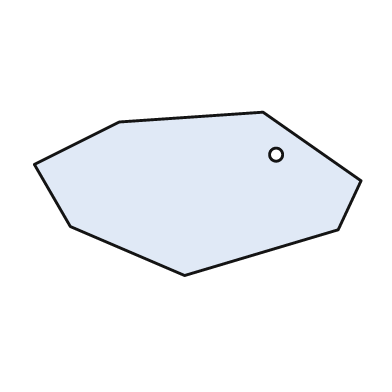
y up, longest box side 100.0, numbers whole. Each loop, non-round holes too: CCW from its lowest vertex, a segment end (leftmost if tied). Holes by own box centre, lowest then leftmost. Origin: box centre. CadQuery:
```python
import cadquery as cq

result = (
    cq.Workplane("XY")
    .moveTo(-4.0, -25.0)
    .lineTo(43.0, -11.0)
    .lineTo(50.0, 4.0)
    .lineTo(20.0, 25.0)
    .lineTo(-24.0, 22.0)
    .lineTo(-50.0, 9.0)
    .lineTo(-39.0, -10.0)
    .close()
    .moveTo(24.0, 12.0)
    .circle(2.0)
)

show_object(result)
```